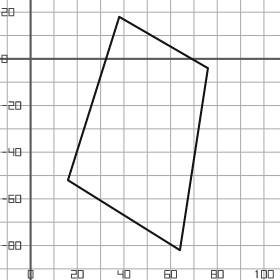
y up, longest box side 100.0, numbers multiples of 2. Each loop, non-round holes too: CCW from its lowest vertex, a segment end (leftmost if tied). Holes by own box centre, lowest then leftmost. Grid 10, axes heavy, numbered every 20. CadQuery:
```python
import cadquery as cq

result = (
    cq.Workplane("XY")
    .moveTo(64.0, -82.0)
    .lineTo(76.0, -4.0)
    .lineTo(38.0, 18.0)
    .lineTo(16.0, -52.0)
    .close()
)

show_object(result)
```